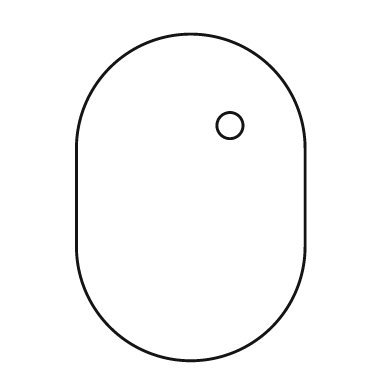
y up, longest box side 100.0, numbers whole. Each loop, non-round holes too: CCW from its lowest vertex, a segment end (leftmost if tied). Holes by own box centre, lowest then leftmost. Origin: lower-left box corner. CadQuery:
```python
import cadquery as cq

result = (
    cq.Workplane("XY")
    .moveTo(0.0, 35.0)
    .threePointArc((35.0, 0.0), (70.0, 35.0))
    .lineTo(70.0, 65.0)
    .threePointArc((35.0, 100.0), (0.0, 65.0))
    .close()
    .moveTo(47.0, 72.0)
    .circle(4.0)
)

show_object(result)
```